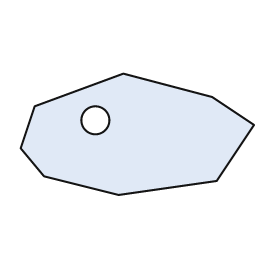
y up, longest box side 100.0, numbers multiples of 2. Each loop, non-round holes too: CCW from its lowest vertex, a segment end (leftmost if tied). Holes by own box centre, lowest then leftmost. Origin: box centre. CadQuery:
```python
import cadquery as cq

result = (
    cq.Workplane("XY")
    .moveTo(-8.0, -26.0)
    .lineTo(34.0, -20.0)
    .lineTo(50.0, 4.0)
    .lineTo(32.0, 16.0)
    .lineTo(-6.0, 26.0)
    .lineTo(-44.0, 12.0)
    .lineTo(-50.0, -6.0)
    .lineTo(-40.0, -18.0)
    .close()
    .moveTo(-18.0, 6.0)
    .circle(6.0)
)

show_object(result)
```